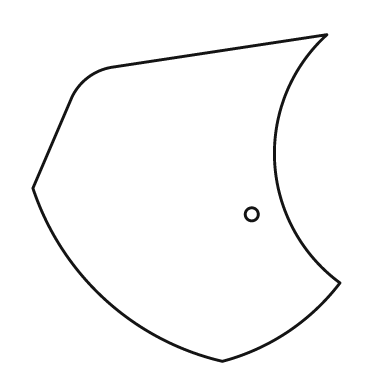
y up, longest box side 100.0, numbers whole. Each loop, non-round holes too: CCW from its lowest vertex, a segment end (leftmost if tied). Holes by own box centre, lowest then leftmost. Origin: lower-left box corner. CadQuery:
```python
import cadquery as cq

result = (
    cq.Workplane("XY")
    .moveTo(58.0, 0.0)
    .threePointArc((78.0, 9.0), (94.0, 24.0))
    .threePointArc((74.0, 61.0), (90.0, 100.0))
    .lineTo(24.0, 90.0)
    .threePointArc((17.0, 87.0), (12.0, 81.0))
    .lineTo(0.0, 53.0)
    .threePointArc((22.0, 19.0), (58.0, 0.0))
    .close()
    .moveTo(67.0, 45.0)
    .circle(2.0)
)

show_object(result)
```